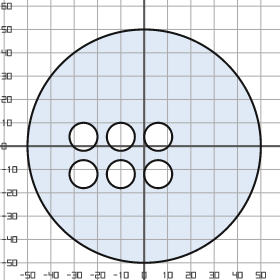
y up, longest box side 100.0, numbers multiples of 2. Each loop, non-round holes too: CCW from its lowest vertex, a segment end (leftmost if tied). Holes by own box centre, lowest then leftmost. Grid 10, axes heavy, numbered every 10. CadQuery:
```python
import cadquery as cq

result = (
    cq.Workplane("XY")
    .moveTo(0.0, 0.0)
    .circle(50.0)
    .moveTo(-26.0, -12.0)
    .circle(6.0)
    .moveTo(-10.0, -12.0)
    .circle(6.0)
    .moveTo(6.0, -12.0)
    .circle(6.0)
    .moveTo(-26.0, 4.0)
    .circle(6.0)
    .moveTo(-10.0, 4.0)
    .circle(6.0)
    .moveTo(6.0, 4.0)
    .circle(6.0)
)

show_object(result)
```